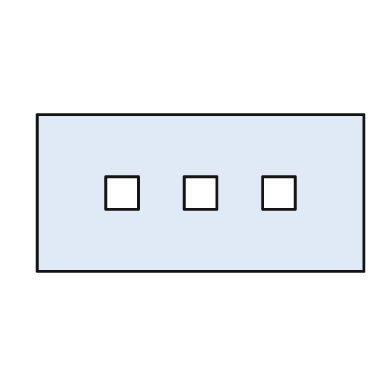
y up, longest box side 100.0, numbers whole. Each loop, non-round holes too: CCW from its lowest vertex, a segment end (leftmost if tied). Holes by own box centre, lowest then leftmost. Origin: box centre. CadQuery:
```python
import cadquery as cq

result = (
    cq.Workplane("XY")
    .moveTo(-50.0, -24.0)
    .lineTo(50.0, -24.0)
    .lineTo(50.0, 24.0)
    .lineTo(-50.0, 24.0)
    .close()
    .moveTo(-29.0, -5.0)
    .lineTo(-19.0, -5.0)
    .lineTo(-19.0, 5.0)
    .lineTo(-29.0, 5.0)
    .close()
    .moveTo(-5.0, -5.0)
    .lineTo(5.0, -5.0)
    .lineTo(5.0, 5.0)
    .lineTo(-5.0, 5.0)
    .close()
    .moveTo(19.0, -5.0)
    .lineTo(29.0, -5.0)
    .lineTo(29.0, 5.0)
    .lineTo(19.0, 5.0)
    .close()
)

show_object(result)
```